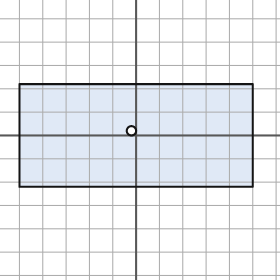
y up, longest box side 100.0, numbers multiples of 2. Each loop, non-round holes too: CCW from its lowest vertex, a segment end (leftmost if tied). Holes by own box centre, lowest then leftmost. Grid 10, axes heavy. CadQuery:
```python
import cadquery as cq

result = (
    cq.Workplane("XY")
    .moveTo(-50.0, -22.0)
    .lineTo(50.0, -22.0)
    .lineTo(50.0, 22.0)
    .lineTo(-50.0, 22.0)
    .close()
    .moveTo(-2.0, 2.0)
    .circle(2.0)
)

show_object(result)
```